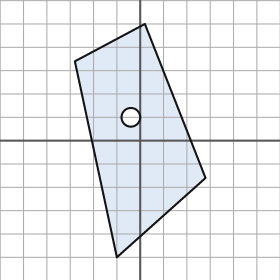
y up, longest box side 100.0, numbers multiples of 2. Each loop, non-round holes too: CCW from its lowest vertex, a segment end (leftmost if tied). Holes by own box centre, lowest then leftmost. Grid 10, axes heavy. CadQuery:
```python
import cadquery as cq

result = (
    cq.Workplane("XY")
    .moveTo(-10.0, -50.0)
    .lineTo(28.0, -16.0)
    .lineTo(2.0, 50.0)
    .lineTo(-28.0, 34.0)
    .close()
    .moveTo(-4.0, 10.0)
    .circle(4.0)
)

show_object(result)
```